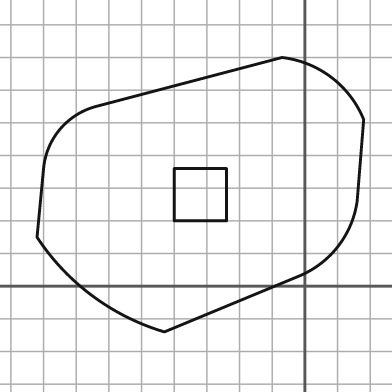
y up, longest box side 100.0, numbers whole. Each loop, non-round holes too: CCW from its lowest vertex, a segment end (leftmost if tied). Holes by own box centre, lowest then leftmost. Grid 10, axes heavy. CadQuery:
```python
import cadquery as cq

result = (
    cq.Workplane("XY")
    .moveTo(-43.0, -14.0)
    .lineTo(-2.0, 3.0)
    .threePointArc((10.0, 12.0), (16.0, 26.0))
    .lineTo(18.0, 51.0)
    .threePointArc((8.0, 64.0), (-7.0, 70.0))
    .lineTo(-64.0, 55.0)
    .threePointArc((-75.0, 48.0), (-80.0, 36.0))
    .lineTo(-82.0, 15.0)
    .threePointArc((-65.0, -3.0), (-43.0, -14.0))
    .close()
    .moveTo(-40.0, 20.0)
    .lineTo(-24.0, 20.0)
    .lineTo(-24.0, 36.0)
    .lineTo(-40.0, 36.0)
    .close()
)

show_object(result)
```